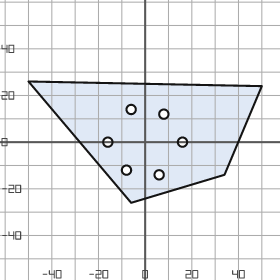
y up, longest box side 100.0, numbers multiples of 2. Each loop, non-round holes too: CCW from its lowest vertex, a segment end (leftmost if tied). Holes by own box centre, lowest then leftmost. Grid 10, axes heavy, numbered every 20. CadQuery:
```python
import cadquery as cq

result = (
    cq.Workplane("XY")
    .moveTo(-6.0, -26.0)
    .lineTo(34.0, -14.0)
    .lineTo(50.0, 24.0)
    .lineTo(-50.0, 26.0)
    .close()
    .moveTo(6.0, -14.0)
    .circle(2.0)
    .moveTo(-8.0, -12.0)
    .circle(2.0)
    .moveTo(-16.0, 0.0)
    .circle(2.0)
    .moveTo(16.0, 0.0)
    .circle(2.0)
    .moveTo(8.0, 12.0)
    .circle(2.0)
    .moveTo(-6.0, 14.0)
    .circle(2.0)
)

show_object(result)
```